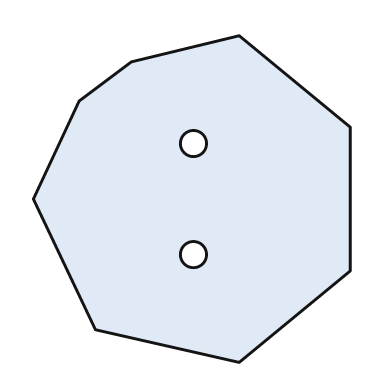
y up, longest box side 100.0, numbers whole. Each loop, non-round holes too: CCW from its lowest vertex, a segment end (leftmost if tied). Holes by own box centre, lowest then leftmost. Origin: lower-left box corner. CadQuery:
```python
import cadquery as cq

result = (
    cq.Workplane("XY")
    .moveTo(63.0, 0.0)
    .lineTo(97.0, 28.0)
    .lineTo(97.0, 72.0)
    .lineTo(63.0, 100.0)
    .lineTo(30.0, 92.0)
    .lineTo(14.0, 80.0)
    .lineTo(0.0, 50.0)
    .lineTo(19.0, 10.0)
    .close()
    .moveTo(49.0, 33.0)
    .circle(4.0)
    .moveTo(49.0, 67.0)
    .circle(4.0)
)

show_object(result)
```